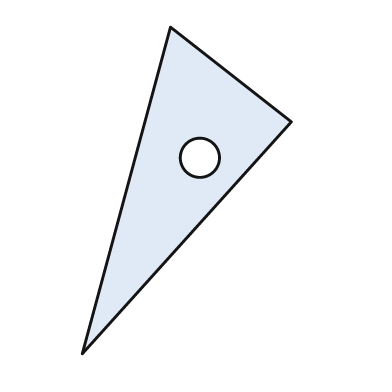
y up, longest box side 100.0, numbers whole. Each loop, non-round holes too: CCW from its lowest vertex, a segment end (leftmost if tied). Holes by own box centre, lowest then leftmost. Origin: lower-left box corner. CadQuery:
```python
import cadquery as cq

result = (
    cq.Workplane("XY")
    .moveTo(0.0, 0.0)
    .lineTo(64.0, 71.0)
    .lineTo(27.0, 100.0)
    .close()
    .moveTo(36.0, 60.0)
    .circle(6.0)
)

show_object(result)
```